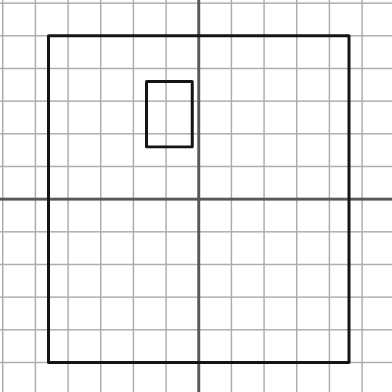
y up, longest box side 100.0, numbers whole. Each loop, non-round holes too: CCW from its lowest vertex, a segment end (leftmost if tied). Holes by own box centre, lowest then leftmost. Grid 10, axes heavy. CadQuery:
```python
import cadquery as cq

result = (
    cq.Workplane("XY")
    .moveTo(-46.0, -50.0)
    .lineTo(46.0, -50.0)
    .lineTo(46.0, 50.0)
    .lineTo(-46.0, 50.0)
    .close()
    .moveTo(-16.0, 16.0)
    .lineTo(-2.0, 16.0)
    .lineTo(-2.0, 36.0)
    .lineTo(-16.0, 36.0)
    .close()
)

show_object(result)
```